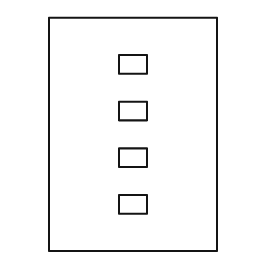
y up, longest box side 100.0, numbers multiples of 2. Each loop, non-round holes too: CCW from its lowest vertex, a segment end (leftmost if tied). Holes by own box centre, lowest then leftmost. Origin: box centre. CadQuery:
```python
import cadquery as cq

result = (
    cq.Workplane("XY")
    .moveTo(-36.0, -50.0)
    .lineTo(36.0, -50.0)
    .lineTo(36.0, 50.0)
    .lineTo(-36.0, 50.0)
    .close()
    .moveTo(-6.0, -34.0)
    .lineTo(6.0, -34.0)
    .lineTo(6.0, -26.0)
    .lineTo(-6.0, -26.0)
    .close()
    .moveTo(-6.0, -14.0)
    .lineTo(6.0, -14.0)
    .lineTo(6.0, -6.0)
    .lineTo(-6.0, -6.0)
    .close()
    .moveTo(-6.0, 6.0)
    .lineTo(6.0, 6.0)
    .lineTo(6.0, 14.0)
    .lineTo(-6.0, 14.0)
    .close()
    .moveTo(-6.0, 26.0)
    .lineTo(6.0, 26.0)
    .lineTo(6.0, 34.0)
    .lineTo(-6.0, 34.0)
    .close()
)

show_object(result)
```